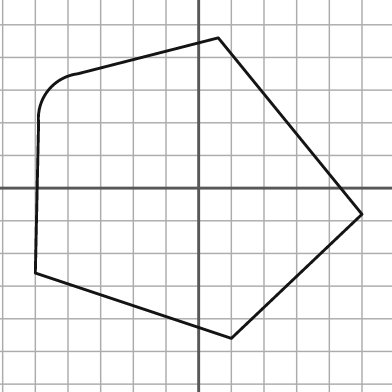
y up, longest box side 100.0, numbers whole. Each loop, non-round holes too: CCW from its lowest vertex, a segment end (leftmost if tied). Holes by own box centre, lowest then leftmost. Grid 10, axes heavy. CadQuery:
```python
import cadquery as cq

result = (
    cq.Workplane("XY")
    .moveTo(10.0, -46.0)
    .lineTo(50.0, -8.0)
    .lineTo(6.0, 46.0)
    .lineTo(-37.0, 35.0)
    .threePointArc((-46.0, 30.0), (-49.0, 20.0))
    .lineTo(-50.0, -26.0)
    .close()
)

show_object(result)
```